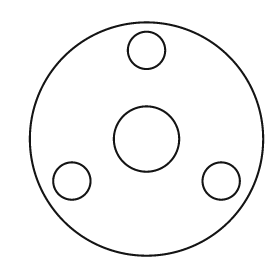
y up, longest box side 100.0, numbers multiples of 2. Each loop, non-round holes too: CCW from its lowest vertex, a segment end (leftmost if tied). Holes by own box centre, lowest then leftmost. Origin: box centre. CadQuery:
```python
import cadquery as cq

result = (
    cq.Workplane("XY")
    .moveTo(0.0, 0.0)
    .circle(50.0)
    .moveTo(-32.0, -18.0)
    .circle(8.0)
    .moveTo(32.0, -18.0)
    .circle(8.0)
    .moveTo(0.0, 0.0)
    .circle(14.0)
    .moveTo(0.0, 38.0)
    .circle(8.0)
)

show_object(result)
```